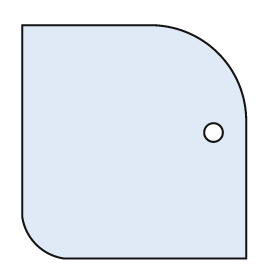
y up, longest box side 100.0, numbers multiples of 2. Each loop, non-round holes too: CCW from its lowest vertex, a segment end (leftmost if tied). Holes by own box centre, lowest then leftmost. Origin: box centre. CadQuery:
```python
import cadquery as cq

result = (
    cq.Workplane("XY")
    .moveTo(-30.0, -50.0)
    .lineTo(48.0, -50.0)
    .lineTo(48.0, 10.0)
    .threePointArc((36.0, 38.0), (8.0, 50.0))
    .lineTo(-48.0, 50.0)
    .lineTo(-48.0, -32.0)
    .threePointArc((-42.0, -44.0), (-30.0, -50.0))
    .close()
    .moveTo(34.0, 4.0)
    .circle(4.0)
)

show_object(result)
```